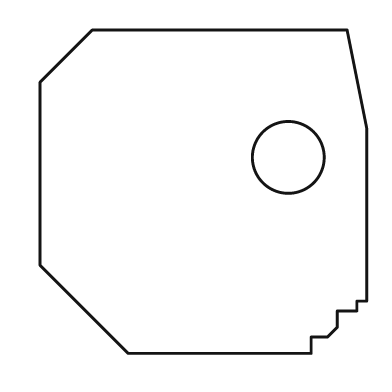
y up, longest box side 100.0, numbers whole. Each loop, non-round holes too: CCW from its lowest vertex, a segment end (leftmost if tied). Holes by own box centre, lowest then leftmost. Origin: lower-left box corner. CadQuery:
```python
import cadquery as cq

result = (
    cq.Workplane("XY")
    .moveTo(27.0, 0.0)
    .lineTo(83.0, 0.0)
    .lineTo(83.0, 5.0)
    .lineTo(88.0, 5.0)
    .lineTo(91.0, 8.0)
    .lineTo(91.0, 13.0)
    .lineTo(97.0, 13.0)
    .lineTo(97.0, 16.0)
    .lineTo(100.0, 16.0)
    .lineTo(100.0, 69.0)
    .lineTo(94.0, 99.0)
    .lineTo(16.0, 99.0)
    .lineTo(0.0, 83.0)
    .lineTo(0.0, 27.0)
    .close()
    .moveTo(76.0, 60.0)
    .circle(11.0)
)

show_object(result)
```